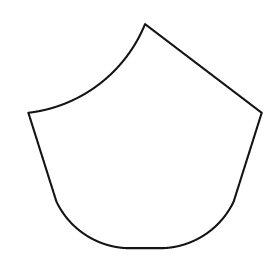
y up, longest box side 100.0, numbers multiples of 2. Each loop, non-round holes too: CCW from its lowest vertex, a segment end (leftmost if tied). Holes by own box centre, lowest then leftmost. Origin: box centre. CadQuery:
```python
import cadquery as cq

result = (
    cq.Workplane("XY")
    .moveTo(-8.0, -48.0)
    .lineTo(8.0, -48.0)
    .threePointArc((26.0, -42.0), (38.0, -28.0))
    .lineTo(50.0, 10.0)
    .lineTo(0.0, 48.0)
    .threePointArc((-20.0, 22.0), (-50.0, 10.0))
    .lineTo(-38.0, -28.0)
    .threePointArc((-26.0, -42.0), (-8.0, -48.0))
    .close()
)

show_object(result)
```